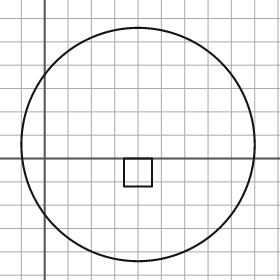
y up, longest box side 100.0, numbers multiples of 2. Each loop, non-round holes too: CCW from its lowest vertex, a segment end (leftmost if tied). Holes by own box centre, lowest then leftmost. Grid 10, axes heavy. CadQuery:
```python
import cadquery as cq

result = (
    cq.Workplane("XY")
    .moveTo(40.0, 6.0)
    .circle(50.0)
    .moveTo(34.0, -12.0)
    .lineTo(46.0, -12.0)
    .lineTo(46.0, 0.0)
    .lineTo(34.0, 0.0)
    .close()
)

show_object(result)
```